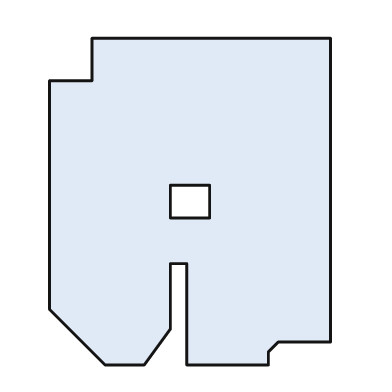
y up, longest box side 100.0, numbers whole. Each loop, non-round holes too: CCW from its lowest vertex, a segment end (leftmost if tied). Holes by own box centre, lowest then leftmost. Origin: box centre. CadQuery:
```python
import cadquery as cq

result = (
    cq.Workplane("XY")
    .moveTo(-26.0, -50.0)
    .lineTo(-14.0, -50.0)
    .lineTo(-6.0, -39.0)
    .lineTo(-6.0, -19.0)
    .lineTo(-1.0, -19.0)
    .lineTo(-1.0, -50.0)
    .lineTo(24.0, -50.0)
    .lineTo(24.0, -46.0)
    .lineTo(27.0, -43.0)
    .lineTo(43.0, -43.0)
    .lineTo(43.0, 50.0)
    .lineTo(-30.0, 50.0)
    .lineTo(-30.0, 37.0)
    .lineTo(-43.0, 37.0)
    .lineTo(-43.0, -33.0)
    .close()
    .moveTo(-6.0, -5.0)
    .lineTo(6.0, -5.0)
    .lineTo(6.0, 5.0)
    .lineTo(-6.0, 5.0)
    .close()
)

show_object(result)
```